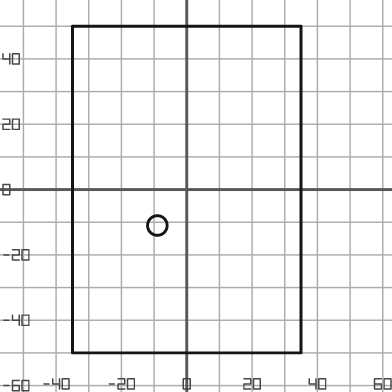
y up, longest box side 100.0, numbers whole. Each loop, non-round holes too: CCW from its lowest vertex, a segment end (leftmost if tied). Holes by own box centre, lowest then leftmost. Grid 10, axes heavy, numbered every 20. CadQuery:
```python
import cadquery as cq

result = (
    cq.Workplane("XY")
    .moveTo(-35.0, -50.0)
    .lineTo(35.0, -50.0)
    .lineTo(35.0, 50.0)
    .lineTo(-35.0, 50.0)
    .close()
    .moveTo(-9.0, -11.0)
    .circle(3.0)
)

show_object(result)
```